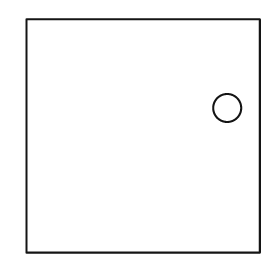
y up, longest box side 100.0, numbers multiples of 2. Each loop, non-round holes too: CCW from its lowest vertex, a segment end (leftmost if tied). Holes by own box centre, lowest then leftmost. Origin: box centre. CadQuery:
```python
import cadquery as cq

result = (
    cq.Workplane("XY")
    .moveTo(-50.0, -50.0)
    .lineTo(50.0, -50.0)
    .lineTo(50.0, 50.0)
    .lineTo(-50.0, 50.0)
    .close()
    .moveTo(36.0, 12.0)
    .circle(6.0)
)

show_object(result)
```